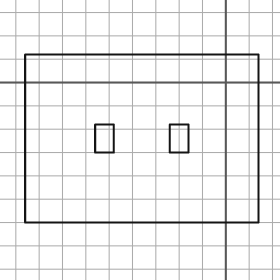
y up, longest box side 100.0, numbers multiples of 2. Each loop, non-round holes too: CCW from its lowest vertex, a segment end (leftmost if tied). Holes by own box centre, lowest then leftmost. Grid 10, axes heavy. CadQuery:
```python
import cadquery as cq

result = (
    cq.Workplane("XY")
    .moveTo(-86.0, -60.0)
    .lineTo(14.0, -60.0)
    .lineTo(14.0, 12.0)
    .lineTo(-86.0, 12.0)
    .close()
    .moveTo(-56.0, -30.0)
    .lineTo(-48.0, -30.0)
    .lineTo(-48.0, -18.0)
    .lineTo(-56.0, -18.0)
    .close()
    .moveTo(-24.0, -30.0)
    .lineTo(-16.0, -30.0)
    .lineTo(-16.0, -18.0)
    .lineTo(-24.0, -18.0)
    .close()
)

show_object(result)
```